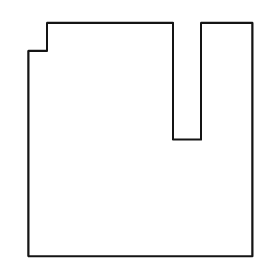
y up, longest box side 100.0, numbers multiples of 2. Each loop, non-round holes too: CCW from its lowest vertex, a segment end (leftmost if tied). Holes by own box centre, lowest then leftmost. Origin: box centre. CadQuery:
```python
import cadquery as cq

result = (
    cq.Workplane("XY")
    .moveTo(-48.0, -50.0)
    .lineTo(48.0, -50.0)
    .lineTo(48.0, 50.0)
    .lineTo(26.0, 50.0)
    .lineTo(26.0, 0.0)
    .lineTo(14.0, 0.0)
    .lineTo(14.0, 50.0)
    .lineTo(-40.0, 50.0)
    .lineTo(-40.0, 38.0)
    .lineTo(-48.0, 38.0)
    .close()
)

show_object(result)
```